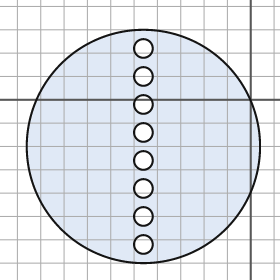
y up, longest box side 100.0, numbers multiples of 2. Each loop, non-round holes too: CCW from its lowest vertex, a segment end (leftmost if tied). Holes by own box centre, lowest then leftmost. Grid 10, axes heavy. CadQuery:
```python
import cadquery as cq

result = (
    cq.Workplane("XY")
    .moveTo(-46.0, -20.0)
    .circle(50.0)
    .moveTo(-46.0, -62.0)
    .circle(4.0)
    .moveTo(-46.0, -50.0)
    .circle(4.0)
    .moveTo(-46.0, -38.0)
    .circle(4.0)
    .moveTo(-46.0, -26.0)
    .circle(4.0)
    .moveTo(-46.0, -14.0)
    .circle(4.0)
    .moveTo(-46.0, -2.0)
    .circle(4.0)
    .moveTo(-46.0, 10.0)
    .circle(4.0)
    .moveTo(-46.0, 22.0)
    .circle(4.0)
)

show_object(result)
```